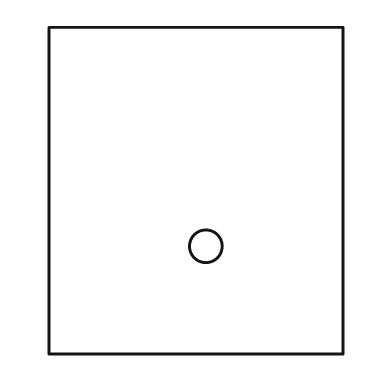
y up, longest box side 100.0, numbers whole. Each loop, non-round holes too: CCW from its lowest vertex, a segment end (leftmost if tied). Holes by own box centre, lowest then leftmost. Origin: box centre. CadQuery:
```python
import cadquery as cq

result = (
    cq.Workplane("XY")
    .moveTo(-45.0, -50.0)
    .lineTo(45.0, -50.0)
    .lineTo(45.0, 50.0)
    .lineTo(-45.0, 50.0)
    .close()
    .moveTo(3.0, -17.0)
    .circle(5.0)
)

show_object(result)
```